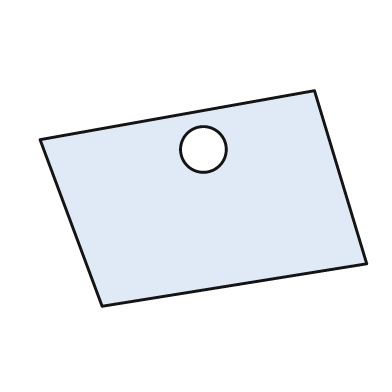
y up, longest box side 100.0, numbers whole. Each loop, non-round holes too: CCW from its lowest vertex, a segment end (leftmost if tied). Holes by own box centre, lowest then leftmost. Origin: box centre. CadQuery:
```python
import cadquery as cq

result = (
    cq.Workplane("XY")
    .moveTo(-31.0, -33.0)
    .lineTo(50.0, -20.0)
    .lineTo(34.0, 33.0)
    .lineTo(-50.0, 18.0)
    .close()
    .moveTo(0.0, 15.0)
    .circle(7.0)
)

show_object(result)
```